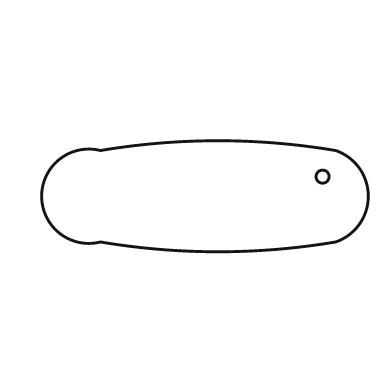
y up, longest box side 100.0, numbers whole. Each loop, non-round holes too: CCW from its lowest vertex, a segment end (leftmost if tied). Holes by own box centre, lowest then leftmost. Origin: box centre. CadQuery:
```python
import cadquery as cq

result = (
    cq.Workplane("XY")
    .moveTo(-32.0, -14.0)
    .threePointArc((4.0, -17.0), (40.0, -14.0))
    .threePointArc((50.0, 0.0), (40.0, 14.0))
    .threePointArc((4.0, 17.0), (-32.0, 14.0))
    .threePointArc((-50.0, 0.0), (-32.0, -14.0))
    .close()
    .moveTo(36.0, 6.0)
    .circle(2.0)
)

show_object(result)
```